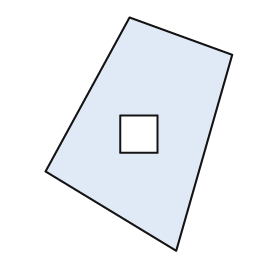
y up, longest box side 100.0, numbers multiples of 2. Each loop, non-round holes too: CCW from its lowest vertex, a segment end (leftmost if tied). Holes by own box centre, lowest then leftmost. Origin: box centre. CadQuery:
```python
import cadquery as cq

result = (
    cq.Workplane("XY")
    .moveTo(16.0, -50.0)
    .lineTo(40.0, 34.0)
    .lineTo(-4.0, 50.0)
    .lineTo(-40.0, -16.0)
    .close()
    .moveTo(-8.0, -8.0)
    .lineTo(8.0, -8.0)
    .lineTo(8.0, 8.0)
    .lineTo(-8.0, 8.0)
    .close()
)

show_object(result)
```